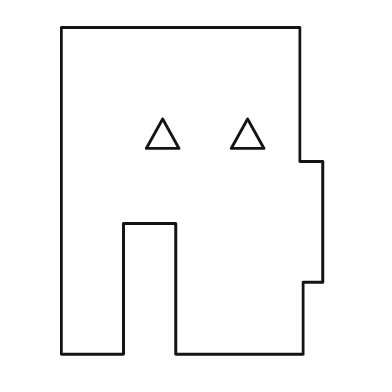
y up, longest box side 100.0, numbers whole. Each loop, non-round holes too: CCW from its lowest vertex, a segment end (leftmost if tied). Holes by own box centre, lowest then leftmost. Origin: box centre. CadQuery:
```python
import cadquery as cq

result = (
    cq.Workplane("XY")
    .moveTo(-40.0, -50.0)
    .lineTo(-21.0, -50.0)
    .lineTo(-21.0, -10.0)
    .lineTo(-5.0, -10.0)
    .lineTo(-5.0, -50.0)
    .lineTo(34.0, -50.0)
    .lineTo(34.0, -28.0)
    .lineTo(40.0, -28.0)
    .lineTo(40.0, 9.0)
    .lineTo(33.0, 9.0)
    .lineTo(33.0, 50.0)
    .lineTo(-40.0, 50.0)
    .close()
    .moveTo(-14.0, 13.0)
    .lineTo(-4.0, 13.0)
    .lineTo(-9.0, 22.0)
    .close()
    .moveTo(12.0, 13.0)
    .lineTo(22.0, 13.0)
    .lineTo(17.0, 22.0)
    .close()
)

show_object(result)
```